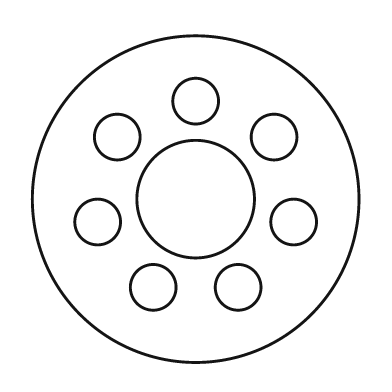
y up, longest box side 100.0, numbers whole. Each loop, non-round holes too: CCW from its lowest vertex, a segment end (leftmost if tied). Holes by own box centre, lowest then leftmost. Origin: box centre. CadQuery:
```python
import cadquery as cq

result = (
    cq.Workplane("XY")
    .moveTo(0.0, 0.0)
    .circle(50.0)
    .moveTo(-13.0, -27.0)
    .circle(7.0)
    .moveTo(13.0, -27.0)
    .circle(7.0)
    .moveTo(-30.0, -7.0)
    .circle(7.0)
    .moveTo(30.0, -7.0)
    .circle(7.0)
    .moveTo(0.0, 0.0)
    .circle(18.0)
    .moveTo(-24.0, 19.0)
    .circle(7.0)
    .moveTo(24.0, 19.0)
    .circle(7.0)
    .moveTo(0.0, 30.0)
    .circle(7.0)
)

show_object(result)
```